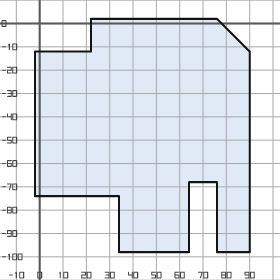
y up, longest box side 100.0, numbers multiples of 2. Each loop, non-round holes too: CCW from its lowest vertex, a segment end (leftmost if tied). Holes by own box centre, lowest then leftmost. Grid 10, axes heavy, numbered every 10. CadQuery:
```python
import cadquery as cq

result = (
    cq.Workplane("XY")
    .moveTo(34.0, -98.0)
    .lineTo(64.0, -98.0)
    .lineTo(64.0, -68.0)
    .lineTo(76.0, -68.0)
    .lineTo(76.0, -98.0)
    .lineTo(90.0, -98.0)
    .lineTo(90.0, -12.0)
    .lineTo(76.0, 2.0)
    .lineTo(22.0, 2.0)
    .lineTo(22.0, -12.0)
    .lineTo(-2.0, -12.0)
    .lineTo(-2.0, -74.0)
    .lineTo(34.0, -74.0)
    .close()
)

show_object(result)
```